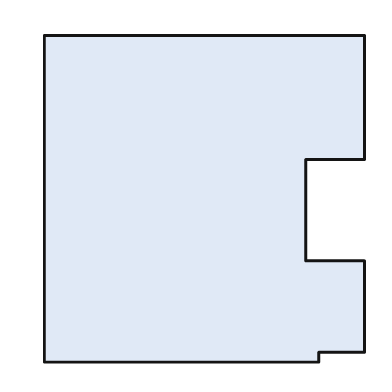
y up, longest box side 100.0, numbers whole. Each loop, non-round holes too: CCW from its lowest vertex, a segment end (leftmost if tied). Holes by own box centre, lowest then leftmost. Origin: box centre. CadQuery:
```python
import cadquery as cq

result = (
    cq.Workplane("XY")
    .moveTo(-49.0, -50.0)
    .lineTo(35.0, -50.0)
    .lineTo(35.0, -47.0)
    .lineTo(49.0, -47.0)
    .lineTo(49.0, -19.0)
    .lineTo(31.0, -19.0)
    .lineTo(31.0, 12.0)
    .lineTo(49.0, 12.0)
    .lineTo(49.0, 50.0)
    .lineTo(-49.0, 50.0)
    .close()
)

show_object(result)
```